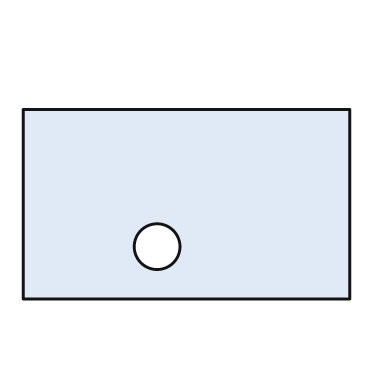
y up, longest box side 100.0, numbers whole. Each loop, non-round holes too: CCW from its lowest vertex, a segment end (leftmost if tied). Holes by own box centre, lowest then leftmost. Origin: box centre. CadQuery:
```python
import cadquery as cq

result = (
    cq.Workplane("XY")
    .moveTo(-50.0, -29.0)
    .lineTo(50.0, -29.0)
    .lineTo(50.0, 29.0)
    .lineTo(-50.0, 29.0)
    .close()
    .moveTo(-9.0, -13.0)
    .circle(7.0)
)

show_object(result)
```